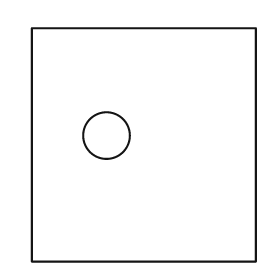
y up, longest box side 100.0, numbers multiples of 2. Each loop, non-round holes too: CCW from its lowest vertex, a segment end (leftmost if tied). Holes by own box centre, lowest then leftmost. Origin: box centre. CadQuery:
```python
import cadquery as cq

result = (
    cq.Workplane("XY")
    .moveTo(-48.0, -50.0)
    .lineTo(48.0, -50.0)
    .lineTo(48.0, 50.0)
    .lineTo(-48.0, 50.0)
    .close()
    .moveTo(-16.0, 4.0)
    .circle(10.0)
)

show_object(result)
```